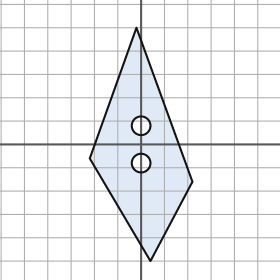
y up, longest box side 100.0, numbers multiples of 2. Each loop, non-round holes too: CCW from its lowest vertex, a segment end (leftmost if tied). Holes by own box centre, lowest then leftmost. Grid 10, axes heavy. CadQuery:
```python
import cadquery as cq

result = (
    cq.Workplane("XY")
    .moveTo(4.0, -50.0)
    .lineTo(22.0, -16.0)
    .lineTo(-2.0, 50.0)
    .lineTo(-22.0, -6.0)
    .close()
    .moveTo(0.0, -8.0)
    .circle(4.0)
    .moveTo(0.0, 8.0)
    .circle(4.0)
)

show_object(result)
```